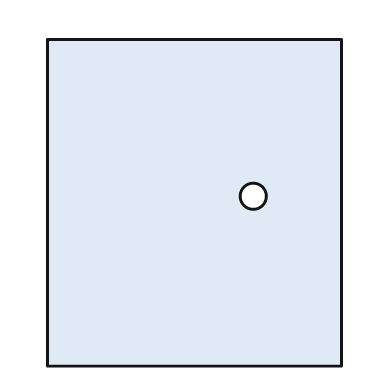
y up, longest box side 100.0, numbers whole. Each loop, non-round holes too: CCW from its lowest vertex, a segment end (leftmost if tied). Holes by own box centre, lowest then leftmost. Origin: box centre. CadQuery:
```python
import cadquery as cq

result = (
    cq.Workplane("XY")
    .moveTo(-45.0, -50.0)
    .lineTo(45.0, -50.0)
    .lineTo(45.0, 50.0)
    .lineTo(-45.0, 50.0)
    .close()
    .moveTo(18.0, 2.0)
    .circle(4.0)
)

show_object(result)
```